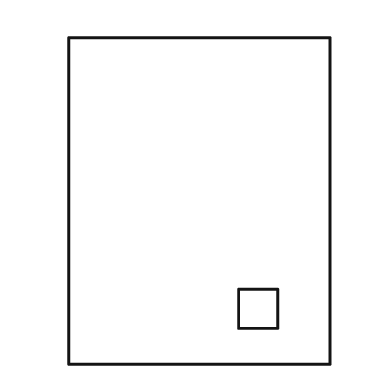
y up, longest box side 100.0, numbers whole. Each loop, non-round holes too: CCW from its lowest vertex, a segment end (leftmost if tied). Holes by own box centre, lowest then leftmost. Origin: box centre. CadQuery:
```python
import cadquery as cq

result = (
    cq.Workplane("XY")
    .moveTo(-40.0, -50.0)
    .lineTo(40.0, -50.0)
    .lineTo(40.0, 50.0)
    .lineTo(-40.0, 50.0)
    .close()
    .moveTo(12.0, -39.0)
    .lineTo(24.0, -39.0)
    .lineTo(24.0, -27.0)
    .lineTo(12.0, -27.0)
    .close()
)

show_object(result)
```